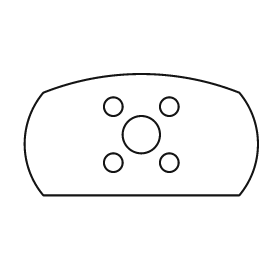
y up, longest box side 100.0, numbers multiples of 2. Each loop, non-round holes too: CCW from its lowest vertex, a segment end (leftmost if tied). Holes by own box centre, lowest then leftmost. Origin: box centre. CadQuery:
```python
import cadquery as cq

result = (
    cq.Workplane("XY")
    .moveTo(-42.0, -26.0)
    .lineTo(42.0, -26.0)
    .threePointArc((50.0, -4.0), (42.0, 18.0))
    .threePointArc((0.0, 26.0), (-42.0, 18.0))
    .threePointArc((-50.0, -4.0), (-42.0, -26.0))
    .close()
    .moveTo(-12.0, -12.0)
    .circle(4.0)
    .moveTo(12.0, -12.0)
    .circle(4.0)
    .moveTo(0.0, 0.0)
    .circle(8.0)
    .moveTo(-12.0, 12.0)
    .circle(4.0)
    .moveTo(12.0, 12.0)
    .circle(4.0)
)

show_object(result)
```